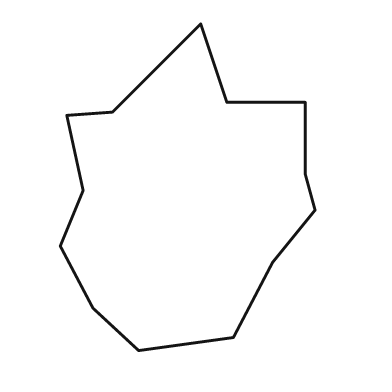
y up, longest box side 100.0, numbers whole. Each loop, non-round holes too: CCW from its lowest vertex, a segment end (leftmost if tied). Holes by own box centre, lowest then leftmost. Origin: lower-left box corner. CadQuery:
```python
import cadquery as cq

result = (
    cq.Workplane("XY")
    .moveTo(24.0, 0.0)
    .lineTo(53.0, 4.0)
    .lineTo(65.0, 27.0)
    .lineTo(78.0, 43.0)
    .lineTo(75.0, 54.0)
    .lineTo(75.0, 76.0)
    .lineTo(51.0, 76.0)
    .lineTo(43.0, 100.0)
    .lineTo(16.0, 73.0)
    .lineTo(2.0, 72.0)
    .lineTo(7.0, 49.0)
    .lineTo(0.0, 32.0)
    .lineTo(10.0, 13.0)
    .close()
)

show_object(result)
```